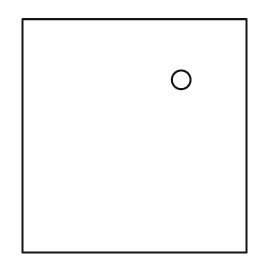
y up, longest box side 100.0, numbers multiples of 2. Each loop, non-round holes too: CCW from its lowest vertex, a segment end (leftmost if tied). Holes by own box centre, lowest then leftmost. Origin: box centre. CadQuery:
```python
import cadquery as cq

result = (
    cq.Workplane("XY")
    .moveTo(-48.0, -50.0)
    .lineTo(48.0, -50.0)
    .lineTo(48.0, 50.0)
    .lineTo(-48.0, 50.0)
    .close()
    .moveTo(20.0, 24.0)
    .circle(4.0)
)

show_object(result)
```